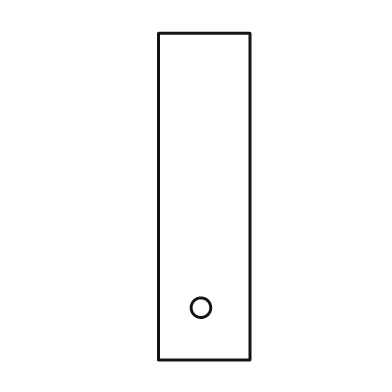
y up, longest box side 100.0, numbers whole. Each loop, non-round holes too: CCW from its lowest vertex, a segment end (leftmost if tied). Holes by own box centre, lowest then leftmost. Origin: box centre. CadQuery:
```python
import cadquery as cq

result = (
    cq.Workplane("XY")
    .moveTo(-14.0, -50.0)
    .lineTo(14.0, -50.0)
    .lineTo(14.0, 50.0)
    .lineTo(-14.0, 50.0)
    .close()
    .moveTo(-1.0, -34.0)
    .circle(3.0)
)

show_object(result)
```